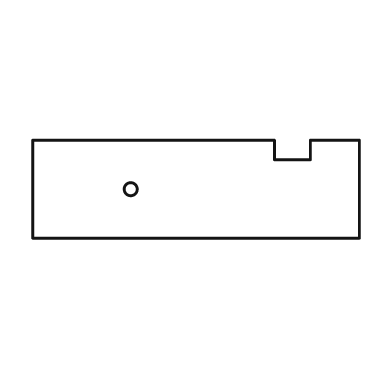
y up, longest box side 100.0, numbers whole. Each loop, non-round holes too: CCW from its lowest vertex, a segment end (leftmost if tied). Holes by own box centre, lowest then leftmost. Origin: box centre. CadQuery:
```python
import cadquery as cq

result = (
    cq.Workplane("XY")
    .moveTo(-50.0, -15.0)
    .lineTo(50.0, -15.0)
    .lineTo(50.0, 15.0)
    .lineTo(35.0, 15.0)
    .lineTo(35.0, 9.0)
    .lineTo(24.0, 9.0)
    .lineTo(24.0, 15.0)
    .lineTo(-50.0, 15.0)
    .close()
    .moveTo(-20.0, 0.0)
    .circle(2.0)
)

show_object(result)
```